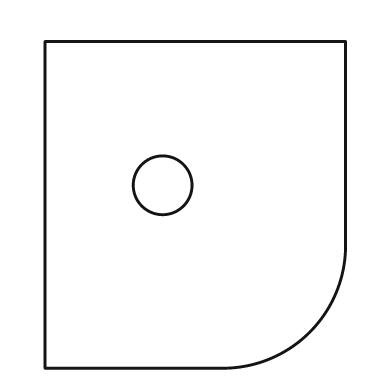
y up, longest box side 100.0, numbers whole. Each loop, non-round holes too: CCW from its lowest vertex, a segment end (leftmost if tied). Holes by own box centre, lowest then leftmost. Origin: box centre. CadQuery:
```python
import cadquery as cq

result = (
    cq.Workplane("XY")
    .moveTo(-46.0, -50.0)
    .lineTo(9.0, -50.0)
    .threePointArc((35.0, -39.0), (46.0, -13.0))
    .lineTo(46.0, 50.0)
    .lineTo(-46.0, 50.0)
    .close()
    .moveTo(-10.0, 6.0)
    .circle(9.0)
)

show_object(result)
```